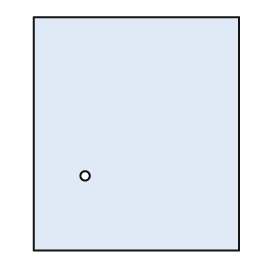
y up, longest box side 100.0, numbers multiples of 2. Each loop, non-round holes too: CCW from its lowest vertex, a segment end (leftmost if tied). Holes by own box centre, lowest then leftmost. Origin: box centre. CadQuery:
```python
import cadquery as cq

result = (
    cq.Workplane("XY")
    .moveTo(-44.0, -50.0)
    .lineTo(44.0, -50.0)
    .lineTo(44.0, 50.0)
    .lineTo(-44.0, 50.0)
    .close()
    .moveTo(-22.0, -18.0)
    .circle(2.0)
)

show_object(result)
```